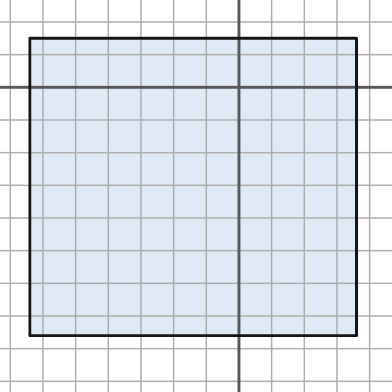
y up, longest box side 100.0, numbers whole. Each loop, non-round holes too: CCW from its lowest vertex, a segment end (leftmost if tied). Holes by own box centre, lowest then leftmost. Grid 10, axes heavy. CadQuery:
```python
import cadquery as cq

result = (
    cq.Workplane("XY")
    .moveTo(-64.0, -76.0)
    .lineTo(36.0, -76.0)
    .lineTo(36.0, 15.0)
    .lineTo(-64.0, 15.0)
    .close()
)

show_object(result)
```